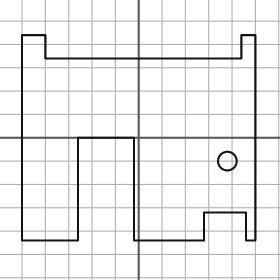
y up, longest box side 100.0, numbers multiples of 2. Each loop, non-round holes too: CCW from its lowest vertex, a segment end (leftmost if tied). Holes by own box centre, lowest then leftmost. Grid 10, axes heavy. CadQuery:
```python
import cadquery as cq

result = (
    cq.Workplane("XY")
    .moveTo(-50.0, -44.0)
    .lineTo(-26.0, -44.0)
    .lineTo(-26.0, 0.0)
    .lineTo(-2.0, 0.0)
    .lineTo(-2.0, -44.0)
    .lineTo(28.0, -44.0)
    .lineTo(28.0, -32.0)
    .lineTo(46.0, -32.0)
    .lineTo(46.0, -44.0)
    .lineTo(50.0, -44.0)
    .lineTo(50.0, 44.0)
    .lineTo(44.0, 44.0)
    .lineTo(44.0, 34.0)
    .lineTo(-40.0, 34.0)
    .lineTo(-40.0, 44.0)
    .lineTo(-50.0, 44.0)
    .close()
    .moveTo(38.0, -10.0)
    .circle(4.0)
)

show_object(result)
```